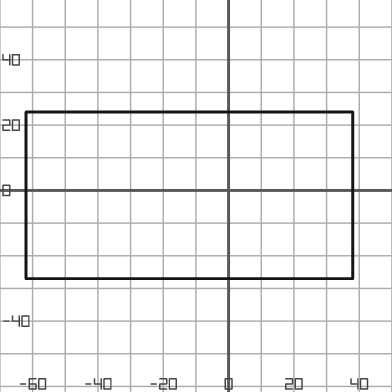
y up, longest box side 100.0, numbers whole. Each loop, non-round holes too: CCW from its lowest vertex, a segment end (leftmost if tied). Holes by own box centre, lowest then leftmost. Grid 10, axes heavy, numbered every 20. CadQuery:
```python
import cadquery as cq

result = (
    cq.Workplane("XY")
    .moveTo(-62.0, -27.0)
    .lineTo(38.0, -27.0)
    .lineTo(38.0, 24.0)
    .lineTo(-62.0, 24.0)
    .close()
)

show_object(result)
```